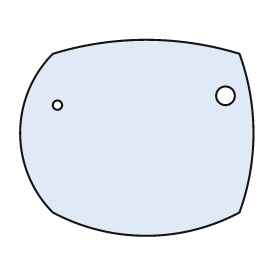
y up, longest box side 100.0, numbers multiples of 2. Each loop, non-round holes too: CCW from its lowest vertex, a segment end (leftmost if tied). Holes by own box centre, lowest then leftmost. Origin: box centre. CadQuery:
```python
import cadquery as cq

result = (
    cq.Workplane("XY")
    .moveTo(-36.0, -32.0)
    .threePointArc((4.0, -42.0), (44.0, -32.0))
    .threePointArc((50.0, 2.0), (44.0, 36.0))
    .threePointArc((4.0, 42.0), (-36.0, 36.0))
    .threePointArc((-50.0, 2.0), (-36.0, -32.0))
    .close()
    .moveTo(-34.0, 14.0)
    .circle(2.0)
    .moveTo(38.0, 18.0)
    .circle(4.0)
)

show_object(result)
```